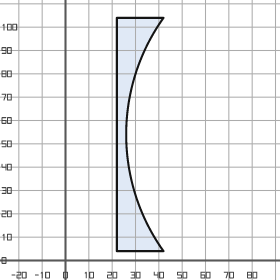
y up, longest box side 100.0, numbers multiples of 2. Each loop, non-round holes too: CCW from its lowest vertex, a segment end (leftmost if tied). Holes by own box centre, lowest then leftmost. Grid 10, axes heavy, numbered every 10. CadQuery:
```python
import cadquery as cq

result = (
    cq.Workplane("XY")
    .moveTo(22.0, 4.0)
    .lineTo(42.0, 4.0)
    .threePointArc((26.0, 54.0), (42.0, 104.0))
    .lineTo(22.0, 104.0)
    .close()
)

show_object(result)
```